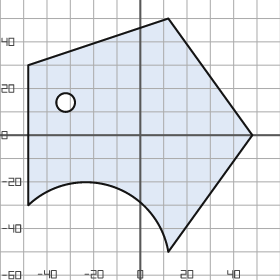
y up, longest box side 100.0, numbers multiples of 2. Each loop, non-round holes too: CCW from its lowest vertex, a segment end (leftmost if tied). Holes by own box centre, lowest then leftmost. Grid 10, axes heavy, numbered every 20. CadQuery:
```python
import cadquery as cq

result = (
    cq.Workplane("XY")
    .moveTo(12.0, -50.0)
    .lineTo(48.0, 0.0)
    .lineTo(12.0, 50.0)
    .lineTo(-48.0, 30.0)
    .lineTo(-48.0, -30.0)
    .threePointArc((-12.0, -22.0), (12.0, -50.0))
    .close()
    .moveTo(-32.0, 14.0)
    .circle(4.0)
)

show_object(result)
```